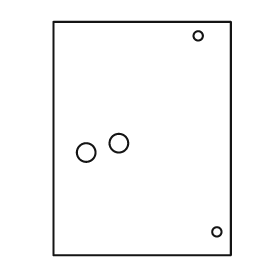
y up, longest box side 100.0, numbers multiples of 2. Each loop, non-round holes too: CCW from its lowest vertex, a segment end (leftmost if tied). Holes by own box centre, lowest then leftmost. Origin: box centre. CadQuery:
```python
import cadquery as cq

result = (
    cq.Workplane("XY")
    .moveTo(-38.0, -50.0)
    .lineTo(38.0, -50.0)
    .lineTo(38.0, 50.0)
    .lineTo(-38.0, 50.0)
    .close()
    .moveTo(32.0, -40.0)
    .circle(2.0)
    .moveTo(-24.0, -6.0)
    .circle(4.0)
    .moveTo(-10.0, -2.0)
    .circle(4.0)
    .moveTo(24.0, 44.0)
    .circle(2.0)
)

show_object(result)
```